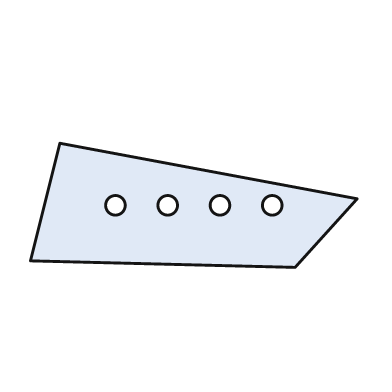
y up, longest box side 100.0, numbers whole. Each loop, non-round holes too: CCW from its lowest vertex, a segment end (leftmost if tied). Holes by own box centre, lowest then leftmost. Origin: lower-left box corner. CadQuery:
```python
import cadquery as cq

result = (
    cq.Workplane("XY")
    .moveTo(81.0, 0.0)
    .lineTo(100.0, 21.0)
    .lineTo(9.0, 38.0)
    .lineTo(0.0, 2.0)
    .close()
    .moveTo(26.0, 19.0)
    .circle(3.0)
    .moveTo(42.0, 19.0)
    .circle(3.0)
    .moveTo(58.0, 19.0)
    .circle(3.0)
    .moveTo(74.0, 19.0)
    .circle(3.0)
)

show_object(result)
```